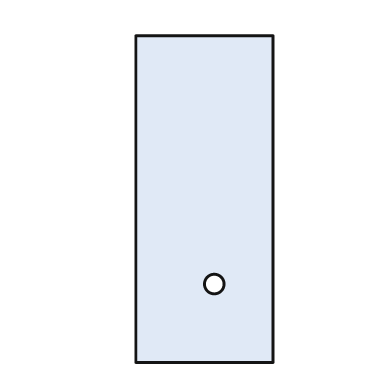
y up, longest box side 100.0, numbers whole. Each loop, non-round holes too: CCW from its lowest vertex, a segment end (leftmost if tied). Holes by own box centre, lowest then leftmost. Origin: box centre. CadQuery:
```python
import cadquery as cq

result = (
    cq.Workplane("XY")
    .moveTo(-21.0, -50.0)
    .lineTo(21.0, -50.0)
    .lineTo(21.0, 50.0)
    .lineTo(-21.0, 50.0)
    .close()
    .moveTo(3.0, -26.0)
    .circle(3.0)
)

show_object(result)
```